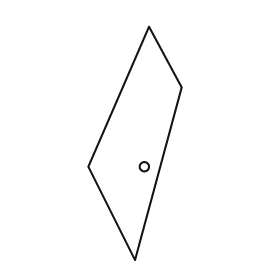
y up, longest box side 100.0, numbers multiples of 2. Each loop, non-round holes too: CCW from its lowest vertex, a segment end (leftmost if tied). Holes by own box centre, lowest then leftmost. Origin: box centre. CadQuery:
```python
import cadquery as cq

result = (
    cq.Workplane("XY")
    .moveTo(0.0, -50.0)
    .lineTo(20.0, 24.0)
    .lineTo(6.0, 50.0)
    .lineTo(-20.0, -10.0)
    .close()
    .moveTo(4.0, -10.0)
    .circle(2.0)
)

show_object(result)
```